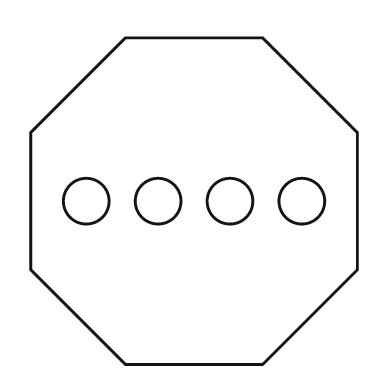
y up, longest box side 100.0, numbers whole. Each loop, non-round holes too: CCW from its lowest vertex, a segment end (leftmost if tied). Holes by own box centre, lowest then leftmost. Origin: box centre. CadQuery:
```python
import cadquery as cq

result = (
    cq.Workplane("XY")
    .moveTo(-21.0, -50.0)
    .lineTo(21.0, -50.0)
    .lineTo(50.0, -21.0)
    .lineTo(50.0, 21.0)
    .lineTo(21.0, 50.0)
    .lineTo(-21.0, 50.0)
    .lineTo(-50.0, 21.0)
    .lineTo(-50.0, -21.0)
    .close()
    .moveTo(-33.0, 0.0)
    .circle(7.0)
    .moveTo(-11.0, 0.0)
    .circle(7.0)
    .moveTo(11.0, 0.0)
    .circle(7.0)
    .moveTo(33.0, 0.0)
    .circle(7.0)
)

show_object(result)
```